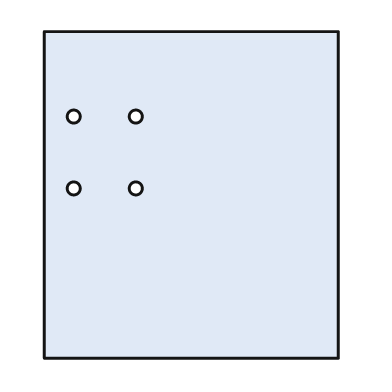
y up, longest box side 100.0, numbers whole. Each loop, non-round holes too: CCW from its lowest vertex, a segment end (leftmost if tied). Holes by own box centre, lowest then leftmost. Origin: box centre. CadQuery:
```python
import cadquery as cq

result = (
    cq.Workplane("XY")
    .moveTo(-45.0, -50.0)
    .lineTo(45.0, -50.0)
    .lineTo(45.0, 50.0)
    .lineTo(-45.0, 50.0)
    .close()
    .moveTo(-36.0, 2.0)
    .circle(2.0)
    .moveTo(-17.0, 2.0)
    .circle(2.0)
    .moveTo(-36.0, 24.0)
    .circle(2.0)
    .moveTo(-17.0, 24.0)
    .circle(2.0)
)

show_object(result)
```